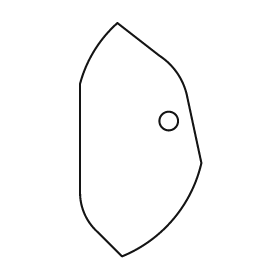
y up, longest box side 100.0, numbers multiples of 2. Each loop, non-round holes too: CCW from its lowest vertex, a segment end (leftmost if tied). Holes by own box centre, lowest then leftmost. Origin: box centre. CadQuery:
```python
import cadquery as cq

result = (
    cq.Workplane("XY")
    .moveTo(-8.0, -50.0)
    .threePointArc((14.0, -34.0), (26.0, -10.0))
    .lineTo(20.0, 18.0)
    .threePointArc((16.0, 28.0), (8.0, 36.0))
    .lineTo(-10.0, 50.0)
    .threePointArc((-20.0, 38.0), (-26.0, 24.0))
    .lineTo(-26.0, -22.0)
    .threePointArc((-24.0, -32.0), (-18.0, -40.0))
    .close()
    .moveTo(12.0, 8.0)
    .circle(4.0)
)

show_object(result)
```